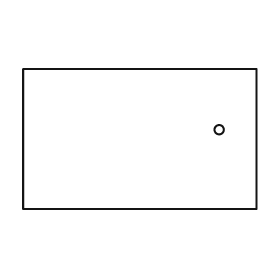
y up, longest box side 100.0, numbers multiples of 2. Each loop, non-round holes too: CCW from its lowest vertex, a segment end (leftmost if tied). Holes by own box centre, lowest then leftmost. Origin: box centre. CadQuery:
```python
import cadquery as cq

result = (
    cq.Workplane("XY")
    .moveTo(-50.0, -30.0)
    .lineTo(50.0, -30.0)
    .lineTo(50.0, 30.0)
    .lineTo(-50.0, 30.0)
    .close()
    .moveTo(34.0, 4.0)
    .circle(2.0)
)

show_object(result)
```